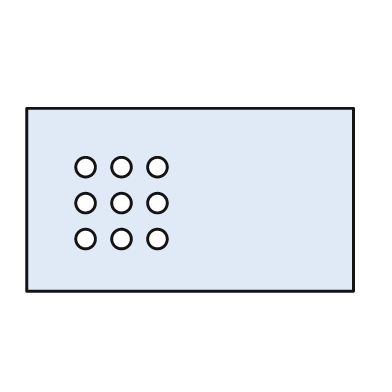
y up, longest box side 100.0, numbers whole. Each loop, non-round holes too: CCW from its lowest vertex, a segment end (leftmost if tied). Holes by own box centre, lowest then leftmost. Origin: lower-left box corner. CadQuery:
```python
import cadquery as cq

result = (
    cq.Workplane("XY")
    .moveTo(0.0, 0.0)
    .lineTo(100.0, 0.0)
    .lineTo(100.0, 56.0)
    .lineTo(0.0, 56.0)
    .close()
    .moveTo(18.0, 16.0)
    .circle(3.0)
    .moveTo(29.0, 16.0)
    .circle(3.0)
    .moveTo(40.0, 16.0)
    .circle(3.0)
    .moveTo(18.0, 27.0)
    .circle(3.0)
    .moveTo(29.0, 27.0)
    .circle(3.0)
    .moveTo(40.0, 27.0)
    .circle(3.0)
    .moveTo(18.0, 38.0)
    .circle(3.0)
    .moveTo(29.0, 38.0)
    .circle(3.0)
    .moveTo(40.0, 38.0)
    .circle(3.0)
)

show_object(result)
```